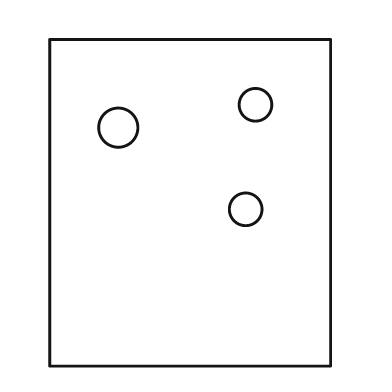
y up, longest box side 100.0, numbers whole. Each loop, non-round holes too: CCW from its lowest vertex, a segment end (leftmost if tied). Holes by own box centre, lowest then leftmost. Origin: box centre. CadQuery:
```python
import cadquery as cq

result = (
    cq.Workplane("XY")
    .moveTo(-43.0, -50.0)
    .lineTo(43.0, -50.0)
    .lineTo(43.0, 50.0)
    .lineTo(-43.0, 50.0)
    .close()
    .moveTo(17.0, -2.0)
    .circle(5.0)
    .moveTo(-22.0, 23.0)
    .circle(6.0)
    .moveTo(20.0, 30.0)
    .circle(5.0)
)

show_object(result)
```